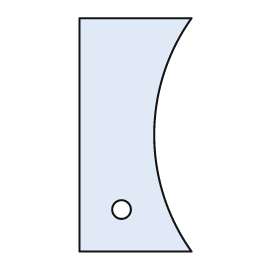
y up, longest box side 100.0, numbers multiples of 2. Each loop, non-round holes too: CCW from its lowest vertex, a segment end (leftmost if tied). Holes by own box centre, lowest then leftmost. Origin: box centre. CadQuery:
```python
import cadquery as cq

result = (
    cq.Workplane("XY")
    .moveTo(-24.0, -50.0)
    .lineTo(24.0, -50.0)
    .threePointArc((8.0, 0.0), (24.0, 50.0))
    .lineTo(-24.0, 50.0)
    .close()
    .moveTo(-6.0, -32.0)
    .circle(4.0)
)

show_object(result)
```